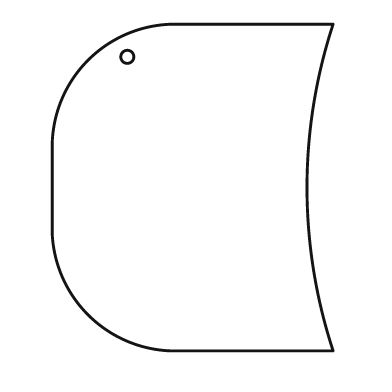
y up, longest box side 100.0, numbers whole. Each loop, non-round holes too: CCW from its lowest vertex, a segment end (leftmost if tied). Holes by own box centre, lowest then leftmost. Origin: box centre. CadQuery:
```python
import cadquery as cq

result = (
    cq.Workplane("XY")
    .moveTo(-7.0, -50.0)
    .lineTo(43.0, -50.0)
    .threePointArc((35.0, 0.0), (43.0, 50.0))
    .lineTo(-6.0, 50.0)
    .threePointArc((-32.0, 39.0), (-43.0, 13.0))
    .lineTo(-43.0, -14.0)
    .threePointArc((-32.0, -39.0), (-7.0, -50.0))
    .close()
    .moveTo(-20.0, 40.0)
    .circle(2.0)
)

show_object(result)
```